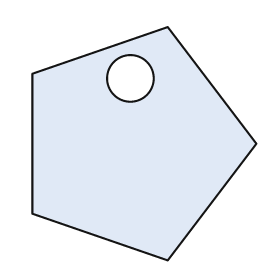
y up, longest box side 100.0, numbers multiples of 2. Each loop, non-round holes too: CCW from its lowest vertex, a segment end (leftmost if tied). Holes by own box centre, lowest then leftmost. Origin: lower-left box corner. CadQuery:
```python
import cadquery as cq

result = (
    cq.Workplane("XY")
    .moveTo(58.0, 0.0)
    .lineTo(96.0, 50.0)
    .lineTo(58.0, 100.0)
    .lineTo(0.0, 80.0)
    .lineTo(0.0, 20.0)
    .close()
    .moveTo(42.0, 78.0)
    .circle(10.0)
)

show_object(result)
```